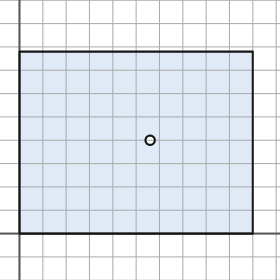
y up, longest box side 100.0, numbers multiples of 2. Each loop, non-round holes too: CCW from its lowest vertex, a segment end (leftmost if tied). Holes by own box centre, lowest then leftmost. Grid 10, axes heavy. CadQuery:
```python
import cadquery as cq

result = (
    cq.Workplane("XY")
    .moveTo(0.0, 0.0)
    .lineTo(100.0, 0.0)
    .lineTo(100.0, 78.0)
    .lineTo(0.0, 78.0)
    .close()
    .moveTo(56.0, 40.0)
    .circle(2.0)
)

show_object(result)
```